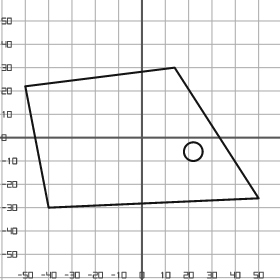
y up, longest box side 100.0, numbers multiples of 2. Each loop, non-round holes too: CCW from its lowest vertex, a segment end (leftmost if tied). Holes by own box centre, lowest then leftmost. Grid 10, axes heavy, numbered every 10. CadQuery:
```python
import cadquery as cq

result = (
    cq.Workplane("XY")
    .moveTo(-40.0, -30.0)
    .lineTo(50.0, -26.0)
    .lineTo(14.0, 30.0)
    .lineTo(-50.0, 22.0)
    .close()
    .moveTo(22.0, -6.0)
    .circle(4.0)
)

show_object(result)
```